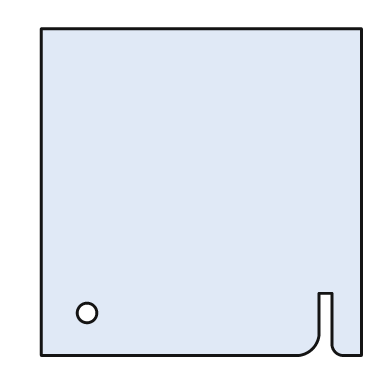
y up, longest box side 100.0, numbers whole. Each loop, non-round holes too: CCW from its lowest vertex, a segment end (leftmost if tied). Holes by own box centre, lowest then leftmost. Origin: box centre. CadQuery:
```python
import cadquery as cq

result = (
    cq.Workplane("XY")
    .moveTo(-49.0, -50.0)
    .lineTo(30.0, -50.0)
    .threePointArc((34.0, -48.0), (36.0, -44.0))
    .lineTo(36.0, -31.0)
    .lineTo(40.0, -31.0)
    .lineTo(40.0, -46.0)
    .threePointArc((41.0, -49.0), (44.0, -50.0))
    .lineTo(49.0, -50.0)
    .lineTo(49.0, 50.0)
    .lineTo(-49.0, 50.0)
    .close()
    .moveTo(-35.0, -37.0)
    .circle(3.0)
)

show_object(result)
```